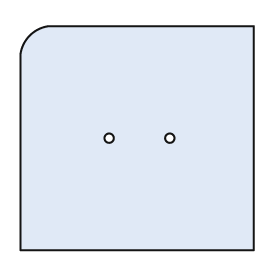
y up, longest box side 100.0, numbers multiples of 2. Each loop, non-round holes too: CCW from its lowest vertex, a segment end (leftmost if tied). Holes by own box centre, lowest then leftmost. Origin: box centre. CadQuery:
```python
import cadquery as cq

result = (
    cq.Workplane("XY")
    .moveTo(-50.0, -48.0)
    .lineTo(50.0, -48.0)
    .lineTo(50.0, 48.0)
    .lineTo(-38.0, 48.0)
    .threePointArc((-46.0, 44.0), (-50.0, 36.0))
    .close()
    .moveTo(-12.0, 0.0)
    .circle(2.0)
    .moveTo(14.0, 0.0)
    .circle(2.0)
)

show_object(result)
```